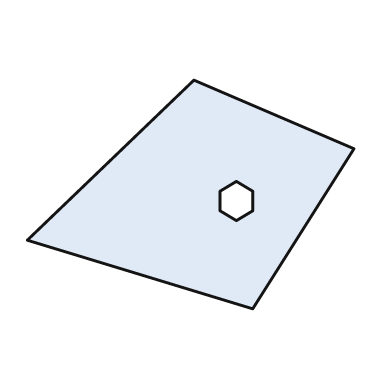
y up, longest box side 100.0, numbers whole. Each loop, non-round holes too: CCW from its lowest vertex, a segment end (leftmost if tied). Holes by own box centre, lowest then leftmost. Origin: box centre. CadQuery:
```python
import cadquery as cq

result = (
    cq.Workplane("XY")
    .moveTo(19.0, -35.0)
    .lineTo(50.0, 14.0)
    .lineTo(1.0, 35.0)
    .lineTo(-50.0, -14.0)
    .close()
    .moveTo(14.0, -8.0)
    .lineTo(19.0, -5.0)
    .lineTo(19.0, 1.0)
    .lineTo(14.0, 4.0)
    .lineTo(9.0, 1.0)
    .lineTo(9.0, -5.0)
    .close()
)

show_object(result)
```